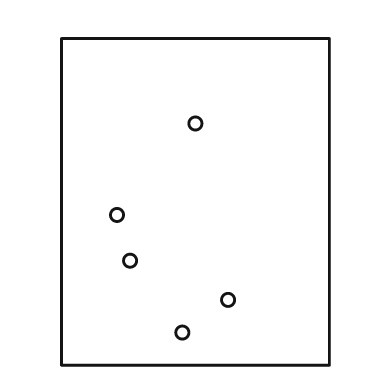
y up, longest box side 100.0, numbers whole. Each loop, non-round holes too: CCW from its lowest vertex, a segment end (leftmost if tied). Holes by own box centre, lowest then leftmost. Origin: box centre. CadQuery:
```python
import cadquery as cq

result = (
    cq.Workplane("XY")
    .moveTo(-41.0, -50.0)
    .lineTo(41.0, -50.0)
    .lineTo(41.0, 50.0)
    .lineTo(-41.0, 50.0)
    .close()
    .moveTo(-4.0, -40.0)
    .circle(2.0)
    .moveTo(10.0, -30.0)
    .circle(2.0)
    .moveTo(-20.0, -18.0)
    .circle(2.0)
    .moveTo(-24.0, -4.0)
    .circle(2.0)
    .moveTo(0.0, 24.0)
    .circle(2.0)
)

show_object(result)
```